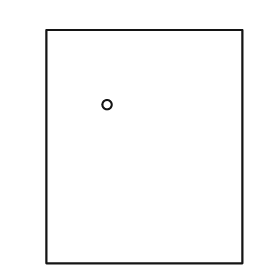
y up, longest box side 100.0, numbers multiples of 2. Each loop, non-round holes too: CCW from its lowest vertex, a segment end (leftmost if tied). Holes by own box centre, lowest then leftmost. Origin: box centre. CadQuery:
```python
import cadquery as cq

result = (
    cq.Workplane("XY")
    .moveTo(-42.0, -50.0)
    .lineTo(42.0, -50.0)
    .lineTo(42.0, 50.0)
    .lineTo(-42.0, 50.0)
    .close()
    .moveTo(-16.0, 18.0)
    .circle(2.0)
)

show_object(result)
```